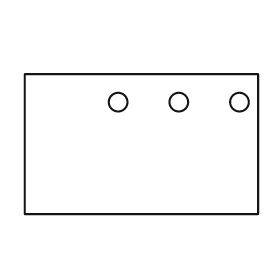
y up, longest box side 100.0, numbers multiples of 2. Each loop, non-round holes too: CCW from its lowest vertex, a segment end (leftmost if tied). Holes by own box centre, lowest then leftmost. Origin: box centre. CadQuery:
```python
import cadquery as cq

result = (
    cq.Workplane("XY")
    .moveTo(-50.0, -30.0)
    .lineTo(50.0, -30.0)
    .lineTo(50.0, 30.0)
    .lineTo(-50.0, 30.0)
    .close()
    .moveTo(-10.0, 18.0)
    .circle(4.0)
    .moveTo(16.0, 18.0)
    .circle(4.0)
    .moveTo(42.0, 18.0)
    .circle(4.0)
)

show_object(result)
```